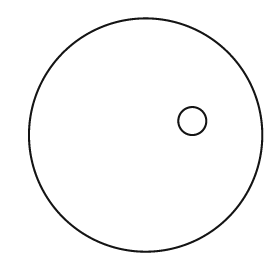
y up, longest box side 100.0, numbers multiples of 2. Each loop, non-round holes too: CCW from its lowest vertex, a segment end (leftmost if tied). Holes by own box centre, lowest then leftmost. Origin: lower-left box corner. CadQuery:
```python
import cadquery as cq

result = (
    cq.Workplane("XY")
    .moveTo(50.0, 50.0)
    .circle(50.0)
    .moveTo(70.0, 56.0)
    .circle(6.0)
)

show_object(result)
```